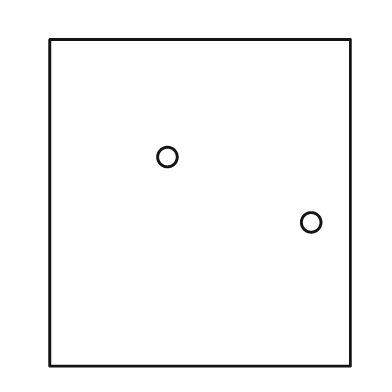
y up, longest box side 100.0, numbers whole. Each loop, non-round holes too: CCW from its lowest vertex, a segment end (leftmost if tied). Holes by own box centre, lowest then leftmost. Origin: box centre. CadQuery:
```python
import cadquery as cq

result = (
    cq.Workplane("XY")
    .moveTo(-46.0, -50.0)
    .lineTo(46.0, -50.0)
    .lineTo(46.0, 50.0)
    .lineTo(-46.0, 50.0)
    .close()
    .moveTo(34.0, -6.0)
    .circle(3.0)
    .moveTo(-10.0, 14.0)
    .circle(3.0)
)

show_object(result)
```